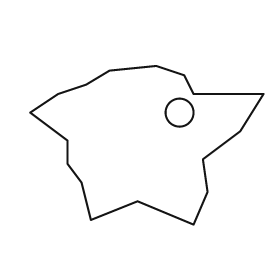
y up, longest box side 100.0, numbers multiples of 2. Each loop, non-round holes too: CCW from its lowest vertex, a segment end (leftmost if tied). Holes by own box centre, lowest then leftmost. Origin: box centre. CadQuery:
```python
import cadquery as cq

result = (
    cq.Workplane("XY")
    .moveTo(20.0, -34.0)
    .lineTo(26.0, -20.0)
    .lineTo(24.0, -6.0)
    .lineTo(40.0, 6.0)
    .lineTo(50.0, 22.0)
    .lineTo(20.0, 22.0)
    .lineTo(16.0, 30.0)
    .lineTo(4.0, 34.0)
    .lineTo(-16.0, 32.0)
    .lineTo(-26.0, 26.0)
    .lineTo(-38.0, 22.0)
    .lineTo(-50.0, 14.0)
    .lineTo(-34.0, 2.0)
    .lineTo(-34.0, -8.0)
    .lineTo(-28.0, -16.0)
    .lineTo(-24.0, -32.0)
    .lineTo(-4.0, -24.0)
    .close()
    .moveTo(14.0, 14.0)
    .circle(6.0)
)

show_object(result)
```